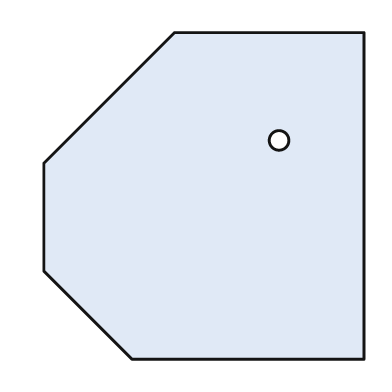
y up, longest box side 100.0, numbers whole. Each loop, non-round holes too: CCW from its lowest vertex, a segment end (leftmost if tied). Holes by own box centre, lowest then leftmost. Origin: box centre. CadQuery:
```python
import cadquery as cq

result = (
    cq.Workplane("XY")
    .moveTo(-22.0, -50.0)
    .lineTo(49.0, -50.0)
    .lineTo(49.0, 50.0)
    .lineTo(-9.0, 50.0)
    .lineTo(-49.0, 10.0)
    .lineTo(-49.0, -23.0)
    .close()
    .moveTo(23.0, 17.0)
    .circle(3.0)
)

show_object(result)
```